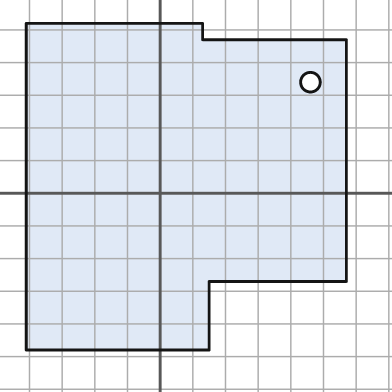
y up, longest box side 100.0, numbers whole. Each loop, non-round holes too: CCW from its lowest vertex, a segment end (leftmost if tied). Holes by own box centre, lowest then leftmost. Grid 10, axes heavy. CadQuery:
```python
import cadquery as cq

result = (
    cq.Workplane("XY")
    .moveTo(-41.0, -48.0)
    .lineTo(15.0, -48.0)
    .lineTo(15.0, -27.0)
    .lineTo(57.0, -27.0)
    .lineTo(57.0, 47.0)
    .lineTo(13.0, 47.0)
    .lineTo(13.0, 52.0)
    .lineTo(-41.0, 52.0)
    .close()
    .moveTo(46.0, 34.0)
    .circle(3.0)
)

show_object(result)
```